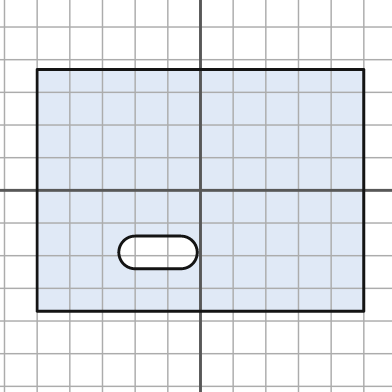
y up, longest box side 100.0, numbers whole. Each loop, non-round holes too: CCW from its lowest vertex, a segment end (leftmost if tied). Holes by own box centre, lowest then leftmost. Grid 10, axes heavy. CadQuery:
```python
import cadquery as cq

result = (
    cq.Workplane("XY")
    .moveTo(-50.0, -37.0)
    .lineTo(50.0, -37.0)
    .lineTo(50.0, 37.0)
    .lineTo(-50.0, 37.0)
    .close()
    .moveTo(-20.0, -24.0)
    .lineTo(-6.0, -24.0)
    .threePointArc((-1.0, -19.0), (-6.0, -14.0))
    .lineTo(-20.0, -14.0)
    .threePointArc((-25.0, -19.0), (-20.0, -24.0))
    .close()
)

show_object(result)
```